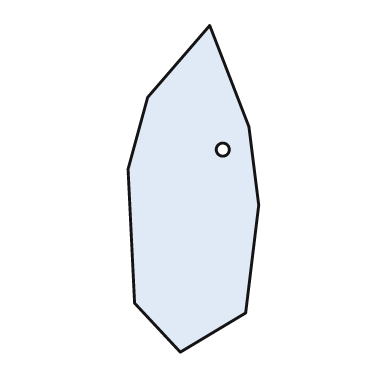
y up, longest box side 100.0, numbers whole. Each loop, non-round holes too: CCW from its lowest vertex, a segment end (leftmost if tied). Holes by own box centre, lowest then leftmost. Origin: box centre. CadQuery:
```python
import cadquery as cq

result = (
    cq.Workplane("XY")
    .moveTo(-4.0, -50.0)
    .lineTo(16.0, -38.0)
    .lineTo(20.0, -5.0)
    .lineTo(17.0, 19.0)
    .lineTo(5.0, 50.0)
    .lineTo(-14.0, 28.0)
    .lineTo(-20.0, 6.0)
    .lineTo(-18.0, -35.0)
    .close()
    .moveTo(9.0, 12.0)
    .circle(2.0)
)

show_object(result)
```